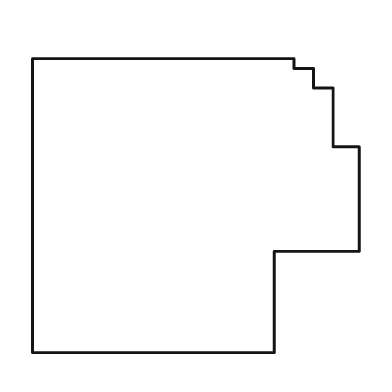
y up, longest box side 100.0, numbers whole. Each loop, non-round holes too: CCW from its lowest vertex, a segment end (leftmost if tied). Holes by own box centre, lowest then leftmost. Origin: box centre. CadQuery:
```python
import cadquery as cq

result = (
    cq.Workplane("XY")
    .moveTo(-50.0, -45.0)
    .lineTo(24.0, -45.0)
    .lineTo(24.0, -14.0)
    .lineTo(50.0, -14.0)
    .lineTo(50.0, 18.0)
    .lineTo(42.0, 18.0)
    .lineTo(42.0, 36.0)
    .lineTo(36.0, 36.0)
    .lineTo(36.0, 42.0)
    .lineTo(30.0, 42.0)
    .lineTo(30.0, 45.0)
    .lineTo(-50.0, 45.0)
    .close()
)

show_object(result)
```